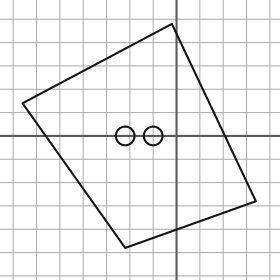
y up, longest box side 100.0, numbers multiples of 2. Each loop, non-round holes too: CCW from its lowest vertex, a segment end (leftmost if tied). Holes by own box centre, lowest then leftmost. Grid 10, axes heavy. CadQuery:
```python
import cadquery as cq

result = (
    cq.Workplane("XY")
    .moveTo(-22.0, -48.0)
    .lineTo(34.0, -28.0)
    .lineTo(-2.0, 48.0)
    .lineTo(-66.0, 14.0)
    .close()
    .moveTo(-22.0, 0.0)
    .circle(4.0)
    .moveTo(-10.0, 0.0)
    .circle(4.0)
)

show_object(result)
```